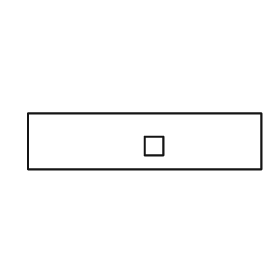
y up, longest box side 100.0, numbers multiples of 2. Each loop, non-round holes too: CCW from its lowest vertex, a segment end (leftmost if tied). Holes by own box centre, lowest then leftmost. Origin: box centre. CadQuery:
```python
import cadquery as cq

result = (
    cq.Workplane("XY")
    .moveTo(-50.0, -12.0)
    .lineTo(50.0, -12.0)
    .lineTo(50.0, 12.0)
    .lineTo(-50.0, 12.0)
    .close()
    .moveTo(0.0, -6.0)
    .lineTo(8.0, -6.0)
    .lineTo(8.0, 2.0)
    .lineTo(0.0, 2.0)
    .close()
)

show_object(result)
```